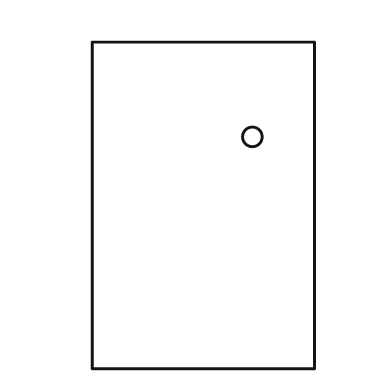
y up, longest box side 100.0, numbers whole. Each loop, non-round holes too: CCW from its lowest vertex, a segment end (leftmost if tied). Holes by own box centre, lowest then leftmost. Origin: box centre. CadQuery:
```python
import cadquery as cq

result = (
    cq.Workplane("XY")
    .moveTo(-34.0, -50.0)
    .lineTo(34.0, -50.0)
    .lineTo(34.0, 50.0)
    .lineTo(-34.0, 50.0)
    .close()
    .moveTo(15.0, 21.0)
    .circle(3.0)
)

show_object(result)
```